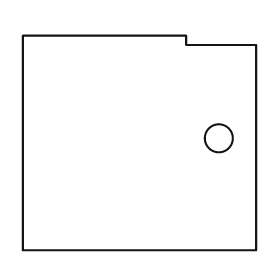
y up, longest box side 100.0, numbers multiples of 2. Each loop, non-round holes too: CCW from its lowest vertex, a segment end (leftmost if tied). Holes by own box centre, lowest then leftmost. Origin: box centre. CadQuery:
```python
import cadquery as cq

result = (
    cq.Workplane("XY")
    .moveTo(-50.0, -46.0)
    .lineTo(50.0, -46.0)
    .lineTo(50.0, 42.0)
    .lineTo(20.0, 42.0)
    .lineTo(20.0, 46.0)
    .lineTo(-50.0, 46.0)
    .close()
    .moveTo(34.0, 2.0)
    .circle(6.0)
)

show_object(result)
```